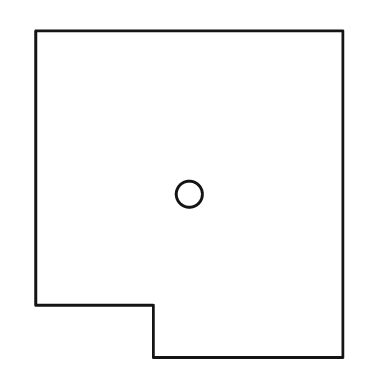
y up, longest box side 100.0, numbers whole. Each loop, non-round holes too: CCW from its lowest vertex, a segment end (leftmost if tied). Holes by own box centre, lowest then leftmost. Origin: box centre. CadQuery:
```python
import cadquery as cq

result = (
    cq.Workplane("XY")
    .moveTo(-11.0, -50.0)
    .lineTo(47.0, -50.0)
    .lineTo(47.0, 50.0)
    .lineTo(-47.0, 50.0)
    .lineTo(-47.0, -34.0)
    .lineTo(-11.0, -34.0)
    .close()
    .moveTo(0.0, 0.0)
    .circle(4.0)
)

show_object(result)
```